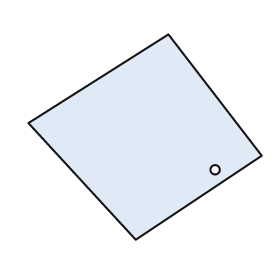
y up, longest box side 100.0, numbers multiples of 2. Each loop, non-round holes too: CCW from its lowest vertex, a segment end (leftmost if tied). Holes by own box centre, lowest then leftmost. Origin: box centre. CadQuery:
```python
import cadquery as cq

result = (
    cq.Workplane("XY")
    .moveTo(-4.0, -44.0)
    .lineTo(50.0, -8.0)
    .lineTo(10.0, 44.0)
    .lineTo(-50.0, 6.0)
    .close()
    .moveTo(30.0, -14.0)
    .circle(2.0)
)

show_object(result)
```